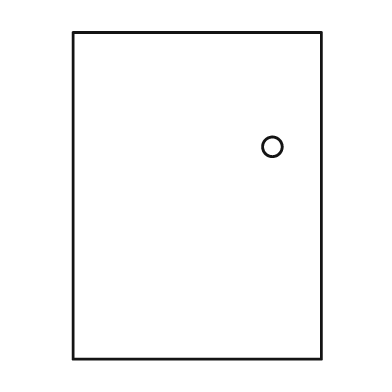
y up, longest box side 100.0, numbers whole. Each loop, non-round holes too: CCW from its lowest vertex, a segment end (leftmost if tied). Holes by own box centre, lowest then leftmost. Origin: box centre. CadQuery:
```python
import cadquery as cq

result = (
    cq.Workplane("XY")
    .moveTo(-38.0, -50.0)
    .lineTo(38.0, -50.0)
    .lineTo(38.0, 50.0)
    .lineTo(-38.0, 50.0)
    .close()
    .moveTo(23.0, 15.0)
    .circle(3.0)
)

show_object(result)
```